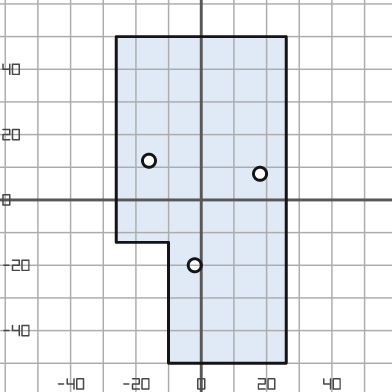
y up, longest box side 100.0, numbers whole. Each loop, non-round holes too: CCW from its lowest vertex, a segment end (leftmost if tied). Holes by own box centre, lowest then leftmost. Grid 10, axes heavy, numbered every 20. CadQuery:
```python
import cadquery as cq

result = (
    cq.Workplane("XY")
    .moveTo(-10.0, -50.0)
    .lineTo(26.0, -50.0)
    .lineTo(26.0, 50.0)
    .lineTo(-26.0, 50.0)
    .lineTo(-26.0, -13.0)
    .lineTo(-10.0, -13.0)
    .close()
    .moveTo(-2.0, -20.0)
    .circle(2.0)
    .moveTo(18.0, 8.0)
    .circle(2.0)
    .moveTo(-16.0, 12.0)
    .circle(2.0)
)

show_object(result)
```